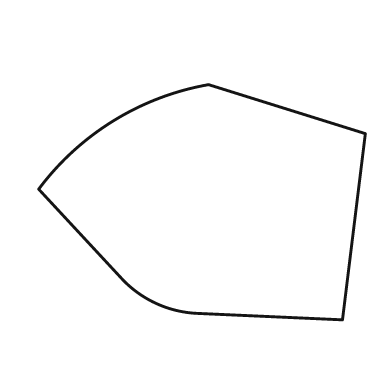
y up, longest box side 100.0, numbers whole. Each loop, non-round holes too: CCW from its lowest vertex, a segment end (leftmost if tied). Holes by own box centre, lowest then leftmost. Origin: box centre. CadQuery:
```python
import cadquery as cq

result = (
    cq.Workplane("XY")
    .moveTo(43.0, -36.0)
    .lineTo(50.0, 21.0)
    .lineTo(2.0, 36.0)
    .threePointArc((-27.0, 25.0), (-50.0, 4.0))
    .lineTo(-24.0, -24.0)
    .threePointArc((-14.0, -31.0), (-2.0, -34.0))
    .close()
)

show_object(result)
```